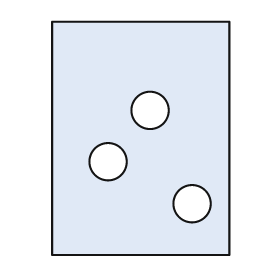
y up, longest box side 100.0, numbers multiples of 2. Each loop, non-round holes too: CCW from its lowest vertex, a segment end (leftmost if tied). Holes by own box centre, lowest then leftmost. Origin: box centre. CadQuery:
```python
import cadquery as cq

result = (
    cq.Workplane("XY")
    .moveTo(-38.0, -50.0)
    .lineTo(38.0, -50.0)
    .lineTo(38.0, 50.0)
    .lineTo(-38.0, 50.0)
    .close()
    .moveTo(22.0, -28.0)
    .circle(8.0)
    .moveTo(-14.0, -10.0)
    .circle(8.0)
    .moveTo(4.0, 12.0)
    .circle(8.0)
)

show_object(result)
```